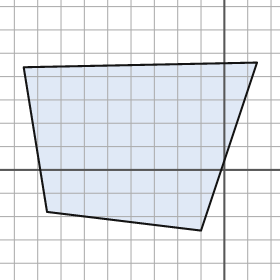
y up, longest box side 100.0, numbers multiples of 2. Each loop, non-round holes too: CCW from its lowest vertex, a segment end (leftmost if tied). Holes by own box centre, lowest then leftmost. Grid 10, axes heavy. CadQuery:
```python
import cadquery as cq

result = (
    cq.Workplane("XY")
    .moveTo(-10.0, -26.0)
    .lineTo(14.0, 46.0)
    .lineTo(-86.0, 44.0)
    .lineTo(-76.0, -18.0)
    .close()
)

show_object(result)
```